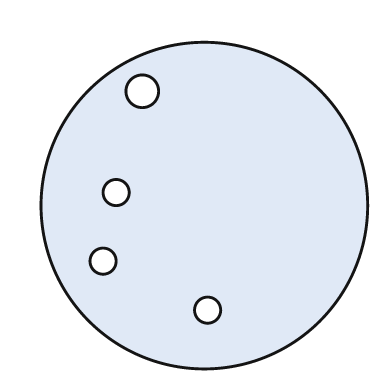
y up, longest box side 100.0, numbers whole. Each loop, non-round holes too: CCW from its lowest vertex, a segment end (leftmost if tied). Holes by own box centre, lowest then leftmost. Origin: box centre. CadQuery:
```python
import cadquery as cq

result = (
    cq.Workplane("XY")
    .moveTo(0.0, 0.0)
    .circle(50.0)
    .moveTo(1.0, -32.0)
    .circle(4.0)
    .moveTo(-31.0, -17.0)
    .circle(4.0)
    .moveTo(-27.0, 4.0)
    .circle(4.0)
    .moveTo(-19.0, 35.0)
    .circle(5.0)
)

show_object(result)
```